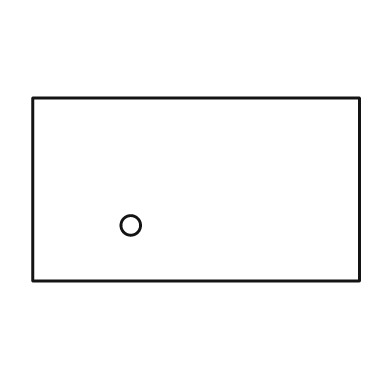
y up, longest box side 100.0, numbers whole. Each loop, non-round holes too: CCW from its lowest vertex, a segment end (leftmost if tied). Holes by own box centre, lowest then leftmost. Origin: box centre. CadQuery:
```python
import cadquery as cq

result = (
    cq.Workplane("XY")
    .moveTo(-50.0, -28.0)
    .lineTo(50.0, -28.0)
    .lineTo(50.0, 28.0)
    .lineTo(-50.0, 28.0)
    .close()
    .moveTo(-20.0, -11.0)
    .circle(3.0)
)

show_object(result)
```